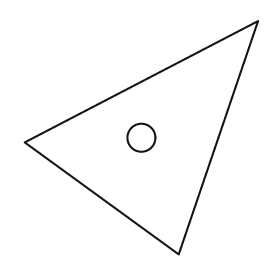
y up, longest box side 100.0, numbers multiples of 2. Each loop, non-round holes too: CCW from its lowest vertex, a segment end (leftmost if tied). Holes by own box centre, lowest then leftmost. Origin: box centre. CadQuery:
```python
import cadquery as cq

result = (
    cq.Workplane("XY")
    .moveTo(16.0, -50.0)
    .lineTo(50.0, 50.0)
    .lineTo(-50.0, -2.0)
    .close()
    .moveTo(0.0, 0.0)
    .circle(6.0)
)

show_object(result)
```